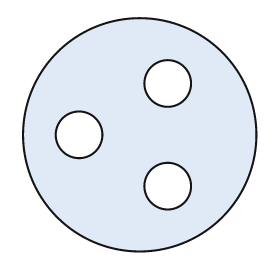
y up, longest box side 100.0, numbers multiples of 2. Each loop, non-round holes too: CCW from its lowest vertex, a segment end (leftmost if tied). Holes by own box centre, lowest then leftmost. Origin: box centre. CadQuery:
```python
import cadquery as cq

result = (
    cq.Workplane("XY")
    .moveTo(0.0, 0.0)
    .circle(50.0)
    .moveTo(12.0, -22.0)
    .circle(10.0)
    .moveTo(-26.0, 0.0)
    .circle(10.0)
    .moveTo(12.0, 22.0)
    .circle(10.0)
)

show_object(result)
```